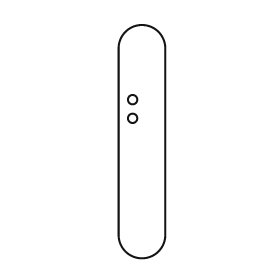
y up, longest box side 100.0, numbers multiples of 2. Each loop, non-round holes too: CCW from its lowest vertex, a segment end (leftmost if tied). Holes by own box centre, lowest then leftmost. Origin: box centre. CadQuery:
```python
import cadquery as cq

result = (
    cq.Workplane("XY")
    .moveTo(-10.0, -40.0)
    .threePointArc((0.0, -50.0), (10.0, -40.0))
    .lineTo(10.0, 40.0)
    .threePointArc((0.0, 50.0), (-10.0, 40.0))
    .close()
    .moveTo(-4.0, 10.0)
    .circle(2.0)
    .moveTo(-4.0, 18.0)
    .circle(2.0)
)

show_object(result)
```